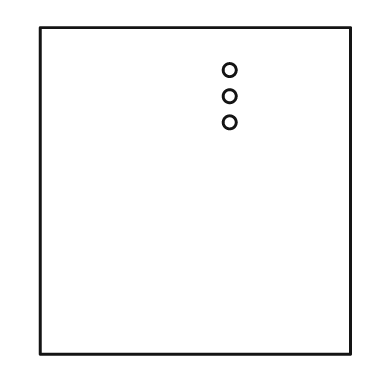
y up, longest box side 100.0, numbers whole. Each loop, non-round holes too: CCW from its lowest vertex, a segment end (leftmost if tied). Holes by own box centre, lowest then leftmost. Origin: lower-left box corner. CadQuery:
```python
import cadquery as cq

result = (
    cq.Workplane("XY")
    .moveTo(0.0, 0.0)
    .lineTo(95.0, 0.0)
    .lineTo(95.0, 100.0)
    .lineTo(0.0, 100.0)
    .close()
    .moveTo(58.0, 71.0)
    .circle(2.0)
    .moveTo(58.0, 79.0)
    .circle(2.0)
    .moveTo(58.0, 87.0)
    .circle(2.0)
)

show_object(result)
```